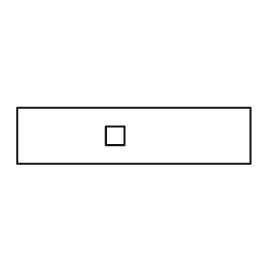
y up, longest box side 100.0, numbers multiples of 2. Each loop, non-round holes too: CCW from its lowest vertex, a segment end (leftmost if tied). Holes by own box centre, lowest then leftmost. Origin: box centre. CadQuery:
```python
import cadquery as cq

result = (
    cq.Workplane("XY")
    .moveTo(-50.0, -12.0)
    .lineTo(50.0, -12.0)
    .lineTo(50.0, 12.0)
    .lineTo(-50.0, 12.0)
    .close()
    .moveTo(-12.0, -4.0)
    .lineTo(-4.0, -4.0)
    .lineTo(-4.0, 4.0)
    .lineTo(-12.0, 4.0)
    .close()
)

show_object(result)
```